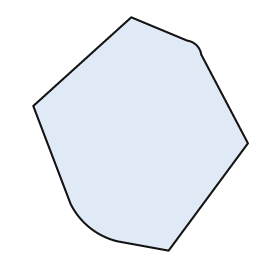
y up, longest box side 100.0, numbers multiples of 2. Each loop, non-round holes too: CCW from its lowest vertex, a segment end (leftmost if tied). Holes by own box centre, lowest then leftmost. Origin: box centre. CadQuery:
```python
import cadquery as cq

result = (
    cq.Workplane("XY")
    .moveTo(12.0, -50.0)
    .lineTo(46.0, -4.0)
    .lineTo(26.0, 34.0)
    .threePointArc((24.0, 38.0), (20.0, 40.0))
    .lineTo(-4.0, 50.0)
    .lineTo(-46.0, 12.0)
    .lineTo(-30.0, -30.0)
    .threePointArc((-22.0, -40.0), (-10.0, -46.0))
    .close()
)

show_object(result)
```